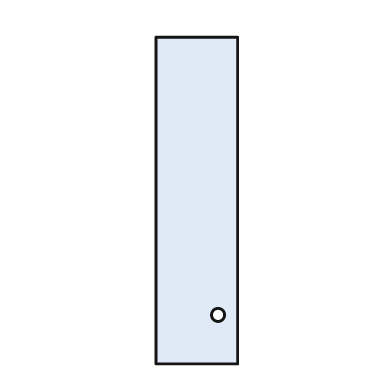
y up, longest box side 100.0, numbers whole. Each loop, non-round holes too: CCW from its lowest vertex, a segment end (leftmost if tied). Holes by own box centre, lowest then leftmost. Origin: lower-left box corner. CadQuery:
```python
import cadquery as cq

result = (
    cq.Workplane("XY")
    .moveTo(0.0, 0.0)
    .lineTo(25.0, 0.0)
    .lineTo(25.0, 100.0)
    .lineTo(0.0, 100.0)
    .close()
    .moveTo(19.0, 15.0)
    .circle(2.0)
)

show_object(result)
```